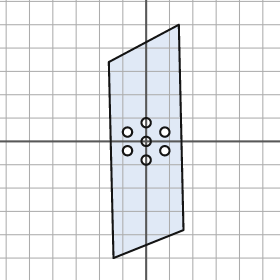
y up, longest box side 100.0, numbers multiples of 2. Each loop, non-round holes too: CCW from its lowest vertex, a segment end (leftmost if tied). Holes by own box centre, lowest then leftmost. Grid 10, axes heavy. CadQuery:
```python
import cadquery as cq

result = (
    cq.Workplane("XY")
    .moveTo(-14.0, -50.0)
    .lineTo(16.0, -38.0)
    .lineTo(14.0, 50.0)
    .lineTo(-16.0, 34.0)
    .close()
    .moveTo(0.0, -8.0)
    .circle(2.0)
    .moveTo(-8.0, -4.0)
    .circle(2.0)
    .moveTo(8.0, -4.0)
    .circle(2.0)
    .moveTo(0.0, 0.0)
    .circle(2.0)
    .moveTo(-8.0, 4.0)
    .circle(2.0)
    .moveTo(8.0, 4.0)
    .circle(2.0)
    .moveTo(0.0, 8.0)
    .circle(2.0)
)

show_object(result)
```